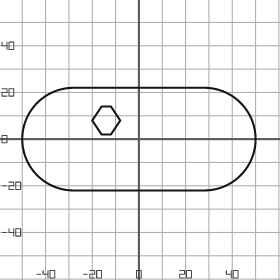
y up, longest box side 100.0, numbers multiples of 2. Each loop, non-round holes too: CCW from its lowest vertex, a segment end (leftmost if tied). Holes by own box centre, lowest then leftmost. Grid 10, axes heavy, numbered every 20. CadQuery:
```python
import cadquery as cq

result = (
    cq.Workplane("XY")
    .moveTo(-28.0, -22.0)
    .lineTo(28.0, -22.0)
    .threePointArc((50.0, 0.0), (28.0, 22.0))
    .lineTo(-28.0, 22.0)
    .threePointArc((-50.0, 0.0), (-28.0, -22.0))
    .close()
    .moveTo(-16.0, 2.0)
    .lineTo(-12.0, 2.0)
    .lineTo(-8.0, 8.0)
    .lineTo(-12.0, 14.0)
    .lineTo(-16.0, 14.0)
    .lineTo(-20.0, 8.0)
    .close()
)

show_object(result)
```